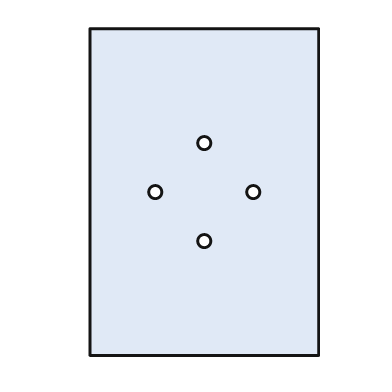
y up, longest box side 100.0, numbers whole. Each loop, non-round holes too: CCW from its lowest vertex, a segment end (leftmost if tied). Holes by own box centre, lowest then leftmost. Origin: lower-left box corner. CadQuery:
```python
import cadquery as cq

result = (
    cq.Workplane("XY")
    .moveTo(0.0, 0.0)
    .lineTo(70.0, 0.0)
    .lineTo(70.0, 100.0)
    .lineTo(0.0, 100.0)
    .close()
    .moveTo(35.0, 35.0)
    .circle(2.0)
    .moveTo(20.0, 50.0)
    .circle(2.0)
    .moveTo(50.0, 50.0)
    .circle(2.0)
    .moveTo(35.0, 65.0)
    .circle(2.0)
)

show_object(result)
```